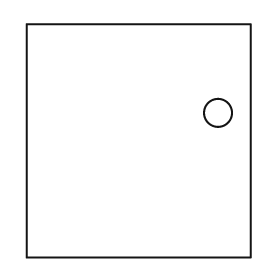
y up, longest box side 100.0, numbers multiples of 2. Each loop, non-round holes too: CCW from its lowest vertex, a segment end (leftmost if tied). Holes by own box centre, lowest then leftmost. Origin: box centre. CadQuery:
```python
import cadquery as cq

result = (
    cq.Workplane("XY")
    .moveTo(-48.0, -50.0)
    .lineTo(48.0, -50.0)
    .lineTo(48.0, 50.0)
    .lineTo(-48.0, 50.0)
    .close()
    .moveTo(34.0, 12.0)
    .circle(6.0)
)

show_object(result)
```